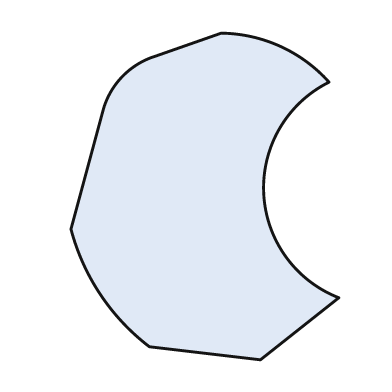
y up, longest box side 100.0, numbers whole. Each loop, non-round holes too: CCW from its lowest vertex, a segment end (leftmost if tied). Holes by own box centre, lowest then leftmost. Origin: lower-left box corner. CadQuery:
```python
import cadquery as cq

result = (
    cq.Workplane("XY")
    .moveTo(58.0, 0.0)
    .lineTo(82.0, 19.0)
    .threePointArc((59.0, 51.0), (79.0, 85.0))
    .threePointArc((64.0, 96.0), (46.0, 100.0))
    .lineTo(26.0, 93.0)
    .threePointArc((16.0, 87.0), (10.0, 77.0))
    .lineTo(0.0, 40.0)
    .threePointArc((9.0, 20.0), (24.0, 4.0))
    .close()
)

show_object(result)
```